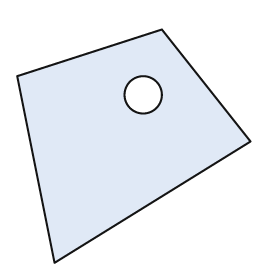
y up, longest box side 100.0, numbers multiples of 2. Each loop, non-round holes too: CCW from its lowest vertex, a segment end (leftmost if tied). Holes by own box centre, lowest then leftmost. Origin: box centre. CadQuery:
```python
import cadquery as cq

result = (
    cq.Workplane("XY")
    .moveTo(-34.0, -50.0)
    .lineTo(50.0, 2.0)
    .lineTo(12.0, 50.0)
    .lineTo(-50.0, 30.0)
    .close()
    .moveTo(4.0, 22.0)
    .circle(8.0)
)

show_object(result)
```